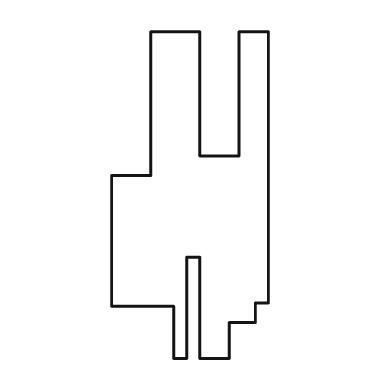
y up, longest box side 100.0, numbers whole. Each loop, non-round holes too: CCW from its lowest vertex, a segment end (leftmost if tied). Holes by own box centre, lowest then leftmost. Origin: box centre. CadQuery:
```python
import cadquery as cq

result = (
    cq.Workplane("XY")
    .moveTo(-5.0, -50.0)
    .lineTo(-1.0, -50.0)
    .lineTo(-1.0, -19.0)
    .lineTo(3.0, -19.0)
    .lineTo(3.0, -50.0)
    .lineTo(12.0, -50.0)
    .lineTo(12.0, -39.0)
    .lineTo(20.0, -39.0)
    .lineTo(20.0, -33.0)
    .lineTo(24.0, -33.0)
    .lineTo(24.0, 50.0)
    .lineTo(15.0, 50.0)
    .lineTo(15.0, 12.0)
    .lineTo(3.0, 12.0)
    .lineTo(3.0, 50.0)
    .lineTo(-12.0, 50.0)
    .lineTo(-12.0, 6.0)
    .lineTo(-24.0, 6.0)
    .lineTo(-24.0, -34.0)
    .lineTo(-5.0, -34.0)
    .close()
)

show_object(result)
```